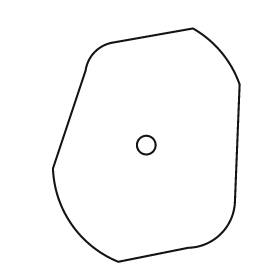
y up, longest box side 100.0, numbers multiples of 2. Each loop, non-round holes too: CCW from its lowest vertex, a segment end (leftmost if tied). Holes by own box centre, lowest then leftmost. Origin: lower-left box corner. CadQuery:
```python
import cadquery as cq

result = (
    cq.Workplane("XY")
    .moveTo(28.0, 0.0)
    .lineTo(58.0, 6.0)
    .threePointArc((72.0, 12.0), (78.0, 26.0))
    .lineTo(80.0, 76.0)
    .threePointArc((72.0, 90.0), (60.0, 100.0))
    .lineTo(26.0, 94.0)
    .threePointArc((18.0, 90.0), (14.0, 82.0))
    .lineTo(0.0, 40.0)
    .threePointArc((8.0, 16.0), (28.0, 0.0))
    .close()
    .moveTo(40.0, 50.0)
    .circle(4.0)
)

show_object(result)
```